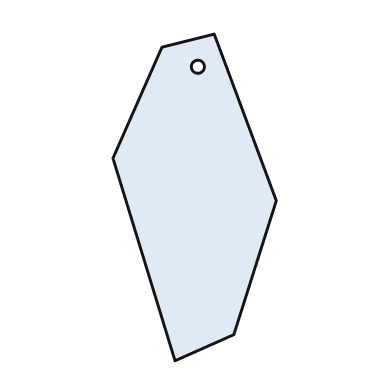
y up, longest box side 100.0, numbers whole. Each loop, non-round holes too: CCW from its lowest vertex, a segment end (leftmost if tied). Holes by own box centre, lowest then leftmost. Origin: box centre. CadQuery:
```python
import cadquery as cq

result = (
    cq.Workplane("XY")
    .moveTo(-6.0, -50.0)
    .lineTo(12.0, -42.0)
    .lineTo(25.0, -1.0)
    .lineTo(6.0, 50.0)
    .lineTo(-10.0, 46.0)
    .lineTo(-25.0, 12.0)
    .close()
    .moveTo(1.0, 40.0)
    .circle(2.0)
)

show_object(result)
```